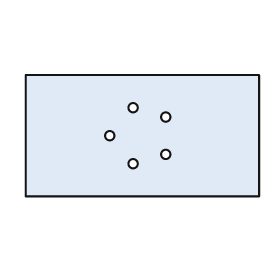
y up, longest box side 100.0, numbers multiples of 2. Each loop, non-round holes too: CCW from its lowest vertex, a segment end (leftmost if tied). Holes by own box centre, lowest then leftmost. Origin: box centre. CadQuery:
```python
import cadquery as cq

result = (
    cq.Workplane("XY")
    .moveTo(-50.0, -26.0)
    .lineTo(50.0, -26.0)
    .lineTo(50.0, 26.0)
    .lineTo(-50.0, 26.0)
    .close()
    .moveTo(-4.0, -12.0)
    .circle(2.0)
    .moveTo(10.0, -8.0)
    .circle(2.0)
    .moveTo(-14.0, 0.0)
    .circle(2.0)
    .moveTo(10.0, 8.0)
    .circle(2.0)
    .moveTo(-4.0, 12.0)
    .circle(2.0)
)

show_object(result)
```